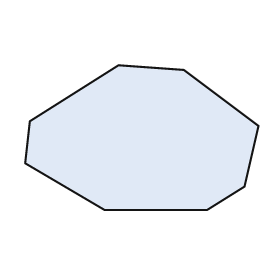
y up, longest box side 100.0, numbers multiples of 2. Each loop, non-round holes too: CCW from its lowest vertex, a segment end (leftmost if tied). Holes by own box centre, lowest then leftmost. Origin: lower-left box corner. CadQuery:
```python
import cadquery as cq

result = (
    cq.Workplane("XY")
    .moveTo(34.0, 0.0)
    .lineTo(78.0, 0.0)
    .lineTo(94.0, 10.0)
    .lineTo(100.0, 36.0)
    .lineTo(68.0, 60.0)
    .lineTo(40.0, 62.0)
    .lineTo(2.0, 38.0)
    .lineTo(0.0, 20.0)
    .close()
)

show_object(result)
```